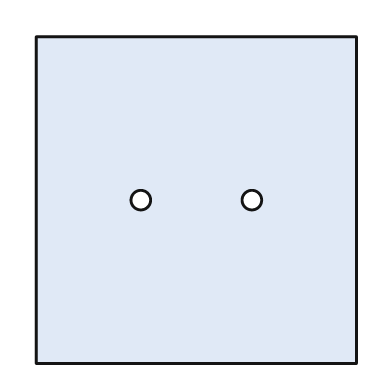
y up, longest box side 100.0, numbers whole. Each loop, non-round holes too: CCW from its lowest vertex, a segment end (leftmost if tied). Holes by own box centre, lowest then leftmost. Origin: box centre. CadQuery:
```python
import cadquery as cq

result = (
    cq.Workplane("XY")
    .moveTo(-49.0, -50.0)
    .lineTo(49.0, -50.0)
    .lineTo(49.0, 50.0)
    .lineTo(-49.0, 50.0)
    .close()
    .moveTo(-17.0, 0.0)
    .circle(3.0)
    .moveTo(17.0, 0.0)
    .circle(3.0)
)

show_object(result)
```